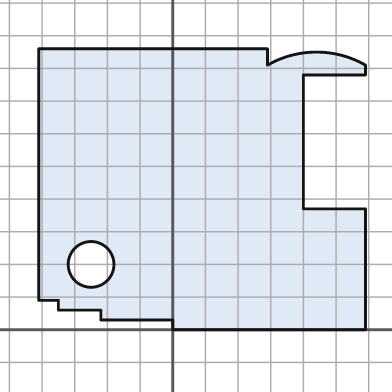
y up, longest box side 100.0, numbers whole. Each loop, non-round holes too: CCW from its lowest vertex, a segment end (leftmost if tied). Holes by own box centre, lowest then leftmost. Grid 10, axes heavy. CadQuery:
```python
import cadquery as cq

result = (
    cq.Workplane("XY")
    .moveTo(0.0, 0.0)
    .lineTo(59.0, 0.0)
    .lineTo(59.0, 37.0)
    .lineTo(40.0, 37.0)
    .lineTo(40.0, 78.0)
    .lineTo(59.0, 78.0)
    .lineTo(59.0, 81.0)
    .threePointArc((44.0, 85.0), (29.0, 81.0))
    .lineTo(29.0, 86.0)
    .lineTo(-41.0, 86.0)
    .lineTo(-41.0, 9.0)
    .lineTo(-35.0, 9.0)
    .lineTo(-35.0, 6.0)
    .lineTo(-22.0, 6.0)
    .lineTo(-22.0, 3.0)
    .lineTo(0.0, 3.0)
    .close()
    .moveTo(-25.0, 20.0)
    .circle(7.0)
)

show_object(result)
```